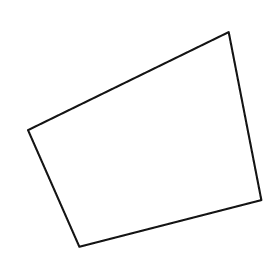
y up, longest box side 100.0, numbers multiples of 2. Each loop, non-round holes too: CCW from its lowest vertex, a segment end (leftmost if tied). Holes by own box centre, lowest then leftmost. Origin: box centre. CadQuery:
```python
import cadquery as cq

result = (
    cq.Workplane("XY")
    .moveTo(-28.0, -46.0)
    .lineTo(50.0, -26.0)
    .lineTo(36.0, 46.0)
    .lineTo(-50.0, 4.0)
    .close()
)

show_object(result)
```